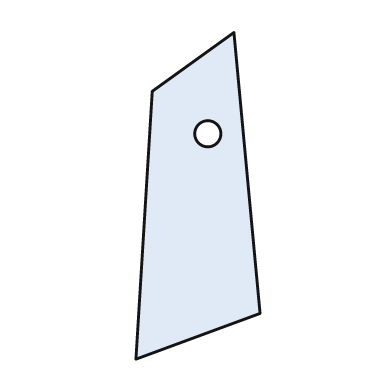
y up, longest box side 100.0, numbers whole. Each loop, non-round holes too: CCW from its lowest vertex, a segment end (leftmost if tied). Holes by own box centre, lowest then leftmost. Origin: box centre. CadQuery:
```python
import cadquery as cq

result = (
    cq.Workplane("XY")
    .moveTo(-19.0, -50.0)
    .lineTo(19.0, -36.0)
    .lineTo(11.0, 50.0)
    .lineTo(-14.0, 32.0)
    .close()
    .moveTo(3.0, 19.0)
    .circle(4.0)
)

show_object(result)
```